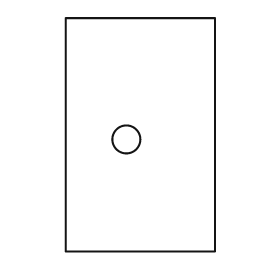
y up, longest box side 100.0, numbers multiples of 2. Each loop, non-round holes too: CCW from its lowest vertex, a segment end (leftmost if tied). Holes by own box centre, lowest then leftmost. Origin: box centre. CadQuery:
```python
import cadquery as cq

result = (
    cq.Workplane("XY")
    .moveTo(-32.0, -50.0)
    .lineTo(32.0, -50.0)
    .lineTo(32.0, 50.0)
    .lineTo(-32.0, 50.0)
    .close()
    .moveTo(-6.0, -2.0)
    .circle(6.0)
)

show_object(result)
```